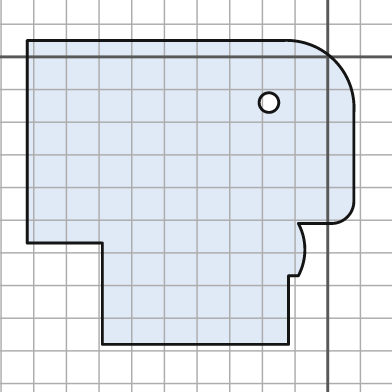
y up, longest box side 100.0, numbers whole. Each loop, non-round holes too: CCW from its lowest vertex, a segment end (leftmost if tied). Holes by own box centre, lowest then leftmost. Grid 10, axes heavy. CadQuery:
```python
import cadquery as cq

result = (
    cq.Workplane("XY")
    .moveTo(-69.0, -88.0)
    .lineTo(-12.0, -88.0)
    .lineTo(-12.0, -67.0)
    .lineTo(-9.0, -67.0)
    .threePointArc((-7.0, -59.0), (-9.0, -51.0))
    .lineTo(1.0, -51.0)
    .threePointArc((6.0, -49.0), (8.0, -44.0))
    .lineTo(8.0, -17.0)
    .threePointArc((2.0, -1.0), (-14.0, 5.0))
    .lineTo(-92.0, 5.0)
    .lineTo(-92.0, -57.0)
    .lineTo(-69.0, -57.0)
    .close()
    .moveTo(-18.0, -14.0)
    .circle(3.0)
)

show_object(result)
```